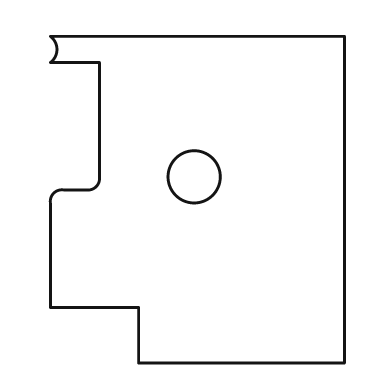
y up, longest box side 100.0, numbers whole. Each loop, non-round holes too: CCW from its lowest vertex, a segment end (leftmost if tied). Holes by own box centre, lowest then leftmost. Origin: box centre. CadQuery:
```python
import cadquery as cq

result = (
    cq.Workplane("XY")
    .moveTo(-18.0, -50.0)
    .lineTo(45.0, -50.0)
    .lineTo(45.0, 50.0)
    .lineTo(-45.0, 50.0)
    .threePointArc((-43.0, 46.0), (-45.0, 42.0))
    .lineTo(-30.0, 42.0)
    .lineTo(-30.0, 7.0)
    .threePointArc((-31.0, 4.0), (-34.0, 3.0))
    .lineTo(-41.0, 3.0)
    .threePointArc((-44.0, 2.0), (-45.0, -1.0))
    .lineTo(-45.0, -33.0)
    .lineTo(-18.0, -33.0)
    .close()
    .moveTo(-1.0, 7.0)
    .circle(8.0)
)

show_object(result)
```